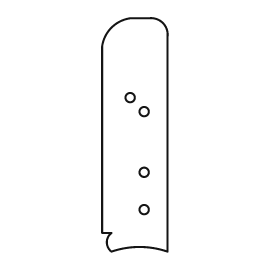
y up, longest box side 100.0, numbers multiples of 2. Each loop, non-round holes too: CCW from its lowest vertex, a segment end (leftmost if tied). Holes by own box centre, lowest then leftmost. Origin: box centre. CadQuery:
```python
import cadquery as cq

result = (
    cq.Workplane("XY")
    .moveTo(-10.0, -50.0)
    .threePointArc((2.0, -48.0), (14.0, -50.0))
    .lineTo(14.0, 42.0)
    .threePointArc((12.0, 48.0), (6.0, 50.0))
    .lineTo(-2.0, 50.0)
    .threePointArc((-10.0, 46.0), (-14.0, 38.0))
    .lineTo(-14.0, -42.0)
    .lineTo(-10.0, -42.0)
    .threePointArc((-12.0, -46.0), (-10.0, -50.0))
    .close()
    .moveTo(4.0, -32.0)
    .circle(2.0)
    .moveTo(4.0, -16.0)
    .circle(2.0)
    .moveTo(4.0, 10.0)
    .circle(2.0)
    .moveTo(-2.0, 16.0)
    .circle(2.0)
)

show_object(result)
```